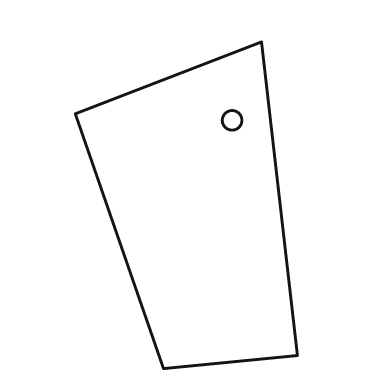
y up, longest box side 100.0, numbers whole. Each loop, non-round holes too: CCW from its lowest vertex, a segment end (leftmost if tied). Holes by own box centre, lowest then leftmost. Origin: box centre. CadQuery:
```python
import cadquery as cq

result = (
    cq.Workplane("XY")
    .moveTo(-7.0, -50.0)
    .lineTo(34.0, -46.0)
    .lineTo(23.0, 50.0)
    .lineTo(-34.0, 28.0)
    .close()
    .moveTo(14.0, 26.0)
    .circle(3.0)
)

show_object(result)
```